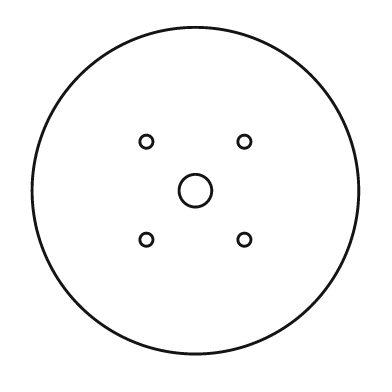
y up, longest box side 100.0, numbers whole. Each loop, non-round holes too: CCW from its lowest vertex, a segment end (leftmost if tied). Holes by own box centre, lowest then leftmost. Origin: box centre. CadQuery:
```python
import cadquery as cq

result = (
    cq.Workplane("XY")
    .moveTo(0.0, 0.0)
    .circle(50.0)
    .moveTo(-15.0, -15.0)
    .circle(2.0)
    .moveTo(15.0, -15.0)
    .circle(2.0)
    .moveTo(0.0, 0.0)
    .circle(5.0)
    .moveTo(-15.0, 15.0)
    .circle(2.0)
    .moveTo(15.0, 15.0)
    .circle(2.0)
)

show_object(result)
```